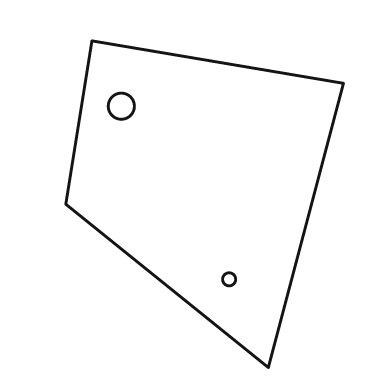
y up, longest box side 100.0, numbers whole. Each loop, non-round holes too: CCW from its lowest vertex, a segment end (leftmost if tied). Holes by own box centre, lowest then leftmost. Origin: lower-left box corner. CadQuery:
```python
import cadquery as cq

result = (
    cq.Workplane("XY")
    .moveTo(62.0, 0.0)
    .lineTo(85.0, 87.0)
    .lineTo(8.0, 100.0)
    .lineTo(0.0, 50.0)
    .close()
    .moveTo(50.0, 27.0)
    .circle(2.0)
    .moveTo(17.0, 80.0)
    .circle(4.0)
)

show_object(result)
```